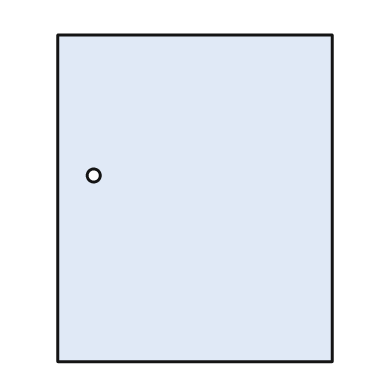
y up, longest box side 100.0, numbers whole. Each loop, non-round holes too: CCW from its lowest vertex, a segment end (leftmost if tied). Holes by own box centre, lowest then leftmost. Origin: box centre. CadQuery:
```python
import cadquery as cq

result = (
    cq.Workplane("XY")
    .moveTo(-42.0, -50.0)
    .lineTo(42.0, -50.0)
    .lineTo(42.0, 50.0)
    .lineTo(-42.0, 50.0)
    .close()
    .moveTo(-31.0, 7.0)
    .circle(2.0)
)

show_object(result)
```